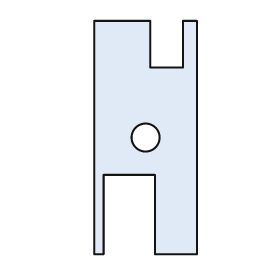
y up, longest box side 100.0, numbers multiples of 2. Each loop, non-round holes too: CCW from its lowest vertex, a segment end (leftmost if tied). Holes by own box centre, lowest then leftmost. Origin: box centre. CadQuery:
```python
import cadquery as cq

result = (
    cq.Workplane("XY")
    .moveTo(-22.0, -50.0)
    .lineTo(-18.0, -50.0)
    .lineTo(-18.0, -16.0)
    .lineTo(4.0, -16.0)
    .lineTo(4.0, -50.0)
    .lineTo(22.0, -50.0)
    .lineTo(22.0, 50.0)
    .lineTo(16.0, 50.0)
    .lineTo(16.0, 30.0)
    .lineTo(2.0, 30.0)
    .lineTo(2.0, 50.0)
    .lineTo(-22.0, 50.0)
    .close()
    .moveTo(0.0, 0.0)
    .circle(6.0)
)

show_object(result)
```